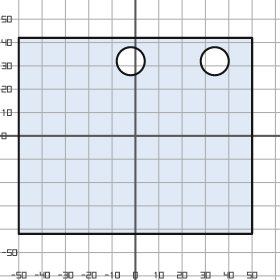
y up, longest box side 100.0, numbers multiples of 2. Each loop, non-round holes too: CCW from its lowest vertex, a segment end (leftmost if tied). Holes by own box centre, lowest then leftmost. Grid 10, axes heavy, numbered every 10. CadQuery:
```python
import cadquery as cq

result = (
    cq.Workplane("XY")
    .moveTo(-50.0, -42.0)
    .lineTo(50.0, -42.0)
    .lineTo(50.0, 42.0)
    .lineTo(-50.0, 42.0)
    .close()
    .moveTo(-2.0, 32.0)
    .circle(6.0)
    .moveTo(34.0, 32.0)
    .circle(6.0)
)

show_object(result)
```